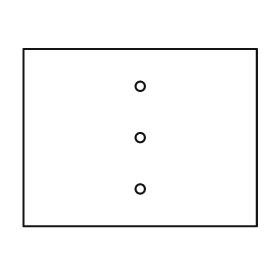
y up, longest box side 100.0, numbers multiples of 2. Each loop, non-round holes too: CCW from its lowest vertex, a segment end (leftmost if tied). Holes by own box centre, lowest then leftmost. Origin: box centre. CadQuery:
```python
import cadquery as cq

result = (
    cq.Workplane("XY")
    .moveTo(-50.0, -38.0)
    .lineTo(50.0, -38.0)
    .lineTo(50.0, 38.0)
    .lineTo(-50.0, 38.0)
    .close()
    .moveTo(0.0, -22.0)
    .circle(2.0)
    .moveTo(0.0, 0.0)
    .circle(2.0)
    .moveTo(0.0, 22.0)
    .circle(2.0)
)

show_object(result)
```